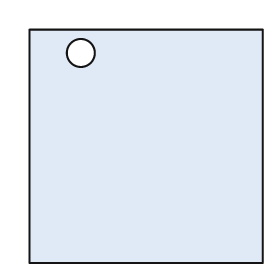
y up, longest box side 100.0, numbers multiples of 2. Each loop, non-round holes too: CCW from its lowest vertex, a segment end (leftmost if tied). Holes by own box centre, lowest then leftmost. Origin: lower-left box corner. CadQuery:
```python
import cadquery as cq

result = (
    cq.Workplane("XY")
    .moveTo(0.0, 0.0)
    .lineTo(100.0, 0.0)
    .lineTo(100.0, 100.0)
    .lineTo(0.0, 100.0)
    .close()
    .moveTo(22.0, 90.0)
    .circle(6.0)
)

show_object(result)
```